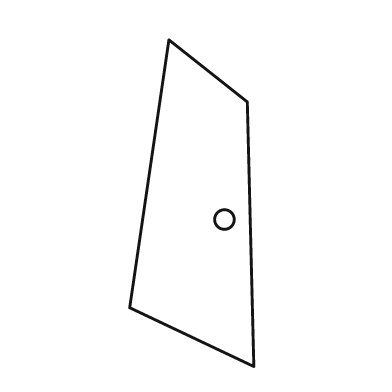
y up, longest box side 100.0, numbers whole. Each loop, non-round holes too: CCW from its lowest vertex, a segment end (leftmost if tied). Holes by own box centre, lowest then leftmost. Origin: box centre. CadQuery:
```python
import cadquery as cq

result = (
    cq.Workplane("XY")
    .moveTo(19.0, -50.0)
    .lineTo(17.0, 31.0)
    .lineTo(-7.0, 50.0)
    .lineTo(-19.0, -32.0)
    .close()
    .moveTo(10.0, -5.0)
    .circle(3.0)
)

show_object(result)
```